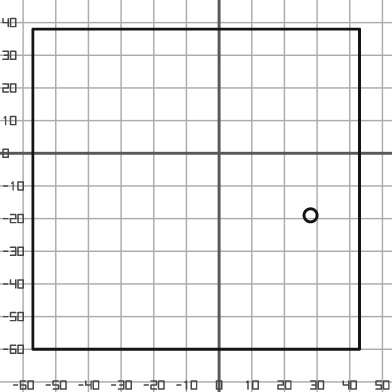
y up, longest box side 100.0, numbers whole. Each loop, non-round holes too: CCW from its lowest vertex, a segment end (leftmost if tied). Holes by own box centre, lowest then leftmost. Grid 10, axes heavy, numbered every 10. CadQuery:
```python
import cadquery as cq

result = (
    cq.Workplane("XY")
    .moveTo(-57.0, -60.0)
    .lineTo(43.0, -60.0)
    .lineTo(43.0, 38.0)
    .lineTo(-57.0, 38.0)
    .close()
    .moveTo(28.0, -19.0)
    .circle(2.0)
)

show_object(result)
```